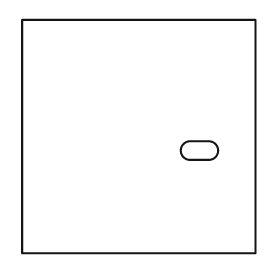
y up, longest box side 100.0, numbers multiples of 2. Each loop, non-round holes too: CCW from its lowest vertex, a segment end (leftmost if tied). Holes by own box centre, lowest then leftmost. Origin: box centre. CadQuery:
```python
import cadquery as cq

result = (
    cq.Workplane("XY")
    .moveTo(-50.0, -50.0)
    .lineTo(50.0, -50.0)
    .lineTo(50.0, 50.0)
    .lineTo(-50.0, 50.0)
    .close()
    .moveTo(22.0, -10.0)
    .lineTo(30.0, -10.0)
    .threePointArc((34.0, -6.0), (30.0, -2.0))
    .lineTo(22.0, -2.0)
    .threePointArc((18.0, -6.0), (22.0, -10.0))
    .close()
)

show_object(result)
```